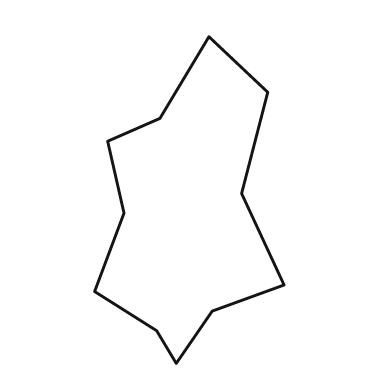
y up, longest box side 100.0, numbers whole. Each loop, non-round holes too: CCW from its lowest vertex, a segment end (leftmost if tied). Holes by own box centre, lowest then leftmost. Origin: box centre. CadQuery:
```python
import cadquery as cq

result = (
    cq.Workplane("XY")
    .moveTo(-4.0, -50.0)
    .lineTo(7.0, -34.0)
    .lineTo(29.0, -26.0)
    .lineTo(16.0, 2.0)
    .lineTo(24.0, 33.0)
    .lineTo(6.0, 50.0)
    .lineTo(-9.0, 25.0)
    .lineTo(-25.0, 18.0)
    .lineTo(-20.0, -4.0)
    .lineTo(-29.0, -28.0)
    .lineTo(-10.0, -40.0)
    .close()
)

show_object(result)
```